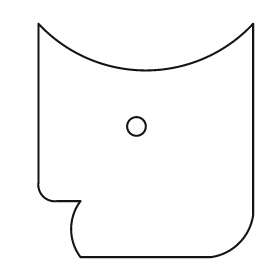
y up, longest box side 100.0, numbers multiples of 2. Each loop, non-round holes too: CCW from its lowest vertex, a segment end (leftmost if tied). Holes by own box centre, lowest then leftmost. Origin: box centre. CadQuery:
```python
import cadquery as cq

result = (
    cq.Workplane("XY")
    .moveTo(-28.0, -50.0)
    .lineTo(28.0, -50.0)
    .threePointArc((40.0, -44.0), (46.0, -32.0))
    .lineTo(46.0, 50.0)
    .threePointArc((0.0, 30.0), (-46.0, 50.0))
    .lineTo(-46.0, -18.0)
    .threePointArc((-44.0, -24.0), (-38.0, -26.0))
    .lineTo(-28.0, -26.0)
    .threePointArc((-32.0, -38.0), (-28.0, -50.0))
    .close()
    .moveTo(-4.0, 6.0)
    .circle(4.0)
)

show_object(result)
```